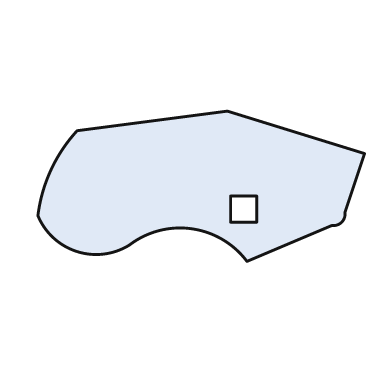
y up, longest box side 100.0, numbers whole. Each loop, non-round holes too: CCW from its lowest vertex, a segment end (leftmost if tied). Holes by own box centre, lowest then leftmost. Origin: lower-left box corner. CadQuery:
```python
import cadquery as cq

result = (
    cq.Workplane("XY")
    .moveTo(64.0, 0.0)
    .lineTo(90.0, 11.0)
    .threePointArc((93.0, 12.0), (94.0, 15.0))
    .lineTo(100.0, 33.0)
    .lineTo(58.0, 46.0)
    .lineTo(12.0, 40.0)
    .threePointArc((4.0, 28.0), (0.0, 14.0))
    .threePointArc((12.0, 3.0), (28.0, 5.0))
    .threePointArc((47.0, 10.0), (64.0, 0.0))
    .close()
    .moveTo(59.0, 12.0)
    .lineTo(67.0, 12.0)
    .lineTo(67.0, 20.0)
    .lineTo(59.0, 20.0)
    .close()
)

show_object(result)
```